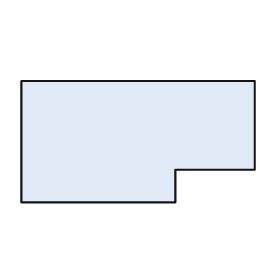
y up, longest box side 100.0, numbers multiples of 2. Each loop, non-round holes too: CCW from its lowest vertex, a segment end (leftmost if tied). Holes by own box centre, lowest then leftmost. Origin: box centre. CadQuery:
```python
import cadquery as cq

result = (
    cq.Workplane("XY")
    .moveTo(-50.0, -26.0)
    .lineTo(16.0, -26.0)
    .lineTo(16.0, -12.0)
    .lineTo(50.0, -12.0)
    .lineTo(50.0, 26.0)
    .lineTo(-50.0, 26.0)
    .close()
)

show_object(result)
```